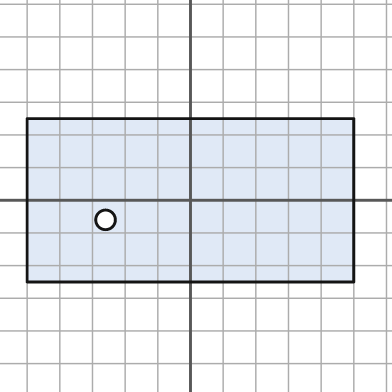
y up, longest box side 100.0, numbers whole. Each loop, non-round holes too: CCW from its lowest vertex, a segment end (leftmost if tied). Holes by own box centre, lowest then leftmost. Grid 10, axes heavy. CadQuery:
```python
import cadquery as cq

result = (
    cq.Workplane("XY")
    .moveTo(-50.0, -25.0)
    .lineTo(50.0, -25.0)
    .lineTo(50.0, 25.0)
    .lineTo(-50.0, 25.0)
    .close()
    .moveTo(-26.0, -6.0)
    .circle(3.0)
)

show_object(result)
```